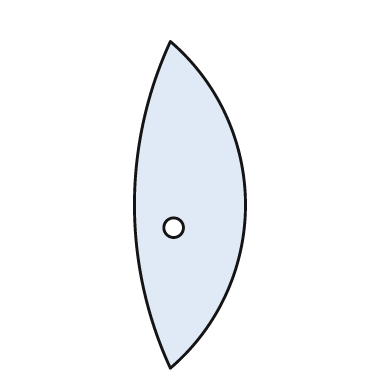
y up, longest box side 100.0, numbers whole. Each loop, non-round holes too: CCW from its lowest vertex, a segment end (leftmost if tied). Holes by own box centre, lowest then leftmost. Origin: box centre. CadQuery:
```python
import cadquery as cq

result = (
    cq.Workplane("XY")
    .moveTo(-6.0, -50.0)
    .threePointArc((17.0, 0.0), (-6.0, 50.0))
    .threePointArc((-17.0, 0.0), (-6.0, -50.0))
    .close()
    .moveTo(-5.0, -7.0)
    .circle(3.0)
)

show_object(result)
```